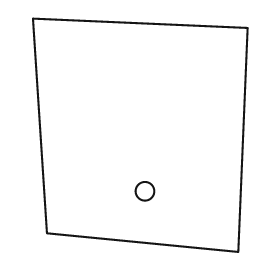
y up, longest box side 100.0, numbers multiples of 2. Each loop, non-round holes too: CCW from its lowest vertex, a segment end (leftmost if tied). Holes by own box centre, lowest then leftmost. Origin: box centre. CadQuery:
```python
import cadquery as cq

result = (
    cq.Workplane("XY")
    .moveTo(42.0, -50.0)
    .lineTo(46.0, 46.0)
    .lineTo(-46.0, 50.0)
    .lineTo(-40.0, -42.0)
    .close()
    .moveTo(2.0, -24.0)
    .circle(4.0)
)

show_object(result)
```